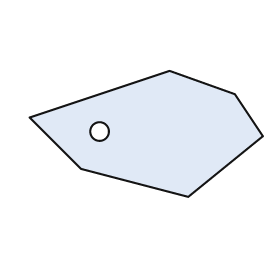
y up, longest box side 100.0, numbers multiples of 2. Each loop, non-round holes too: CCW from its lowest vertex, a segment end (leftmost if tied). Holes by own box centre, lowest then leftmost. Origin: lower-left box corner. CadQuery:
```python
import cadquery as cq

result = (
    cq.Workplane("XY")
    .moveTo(68.0, 0.0)
    .lineTo(100.0, 26.0)
    .lineTo(88.0, 44.0)
    .lineTo(60.0, 54.0)
    .lineTo(0.0, 34.0)
    .lineTo(22.0, 12.0)
    .close()
    .moveTo(30.0, 28.0)
    .circle(4.0)
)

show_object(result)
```